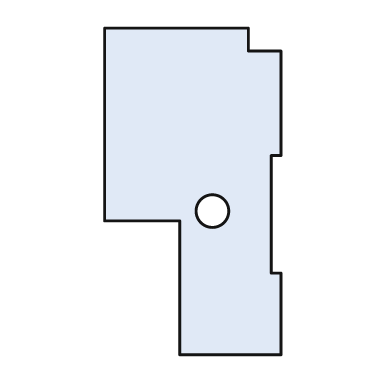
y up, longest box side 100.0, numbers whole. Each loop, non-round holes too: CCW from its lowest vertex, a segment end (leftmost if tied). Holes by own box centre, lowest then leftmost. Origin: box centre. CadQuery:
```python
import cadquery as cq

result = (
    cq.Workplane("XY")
    .moveTo(-4.0, -50.0)
    .lineTo(27.0, -50.0)
    .lineTo(27.0, -25.0)
    .lineTo(24.0, -25.0)
    .lineTo(24.0, 11.0)
    .lineTo(27.0, 11.0)
    .lineTo(27.0, 43.0)
    .lineTo(17.0, 43.0)
    .lineTo(17.0, 50.0)
    .lineTo(-27.0, 50.0)
    .lineTo(-27.0, -9.0)
    .lineTo(-4.0, -9.0)
    .close()
    .moveTo(6.0, -6.0)
    .circle(5.0)
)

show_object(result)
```